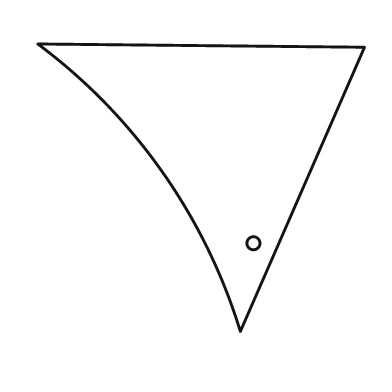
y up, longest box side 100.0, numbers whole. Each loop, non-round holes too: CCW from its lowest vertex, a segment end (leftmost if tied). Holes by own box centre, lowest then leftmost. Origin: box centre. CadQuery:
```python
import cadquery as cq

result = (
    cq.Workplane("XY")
    .moveTo(12.0, -44.0)
    .lineTo(50.0, 43.0)
    .lineTo(-50.0, 44.0)
    .threePointArc((-12.0, 5.0), (12.0, -44.0))
    .close()
    .moveTo(16.0, -17.0)
    .circle(2.0)
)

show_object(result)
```